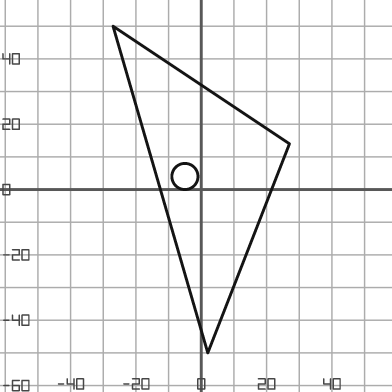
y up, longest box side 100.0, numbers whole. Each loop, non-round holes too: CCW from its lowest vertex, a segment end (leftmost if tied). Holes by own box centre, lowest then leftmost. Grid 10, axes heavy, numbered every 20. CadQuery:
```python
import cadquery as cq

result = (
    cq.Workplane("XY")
    .moveTo(2.0, -50.0)
    .lineTo(27.0, 14.0)
    .lineTo(-27.0, 50.0)
    .close()
    .moveTo(-5.0, 4.0)
    .circle(4.0)
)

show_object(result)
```